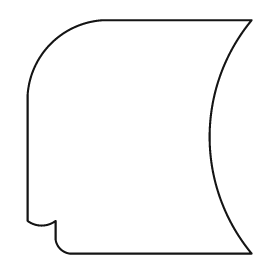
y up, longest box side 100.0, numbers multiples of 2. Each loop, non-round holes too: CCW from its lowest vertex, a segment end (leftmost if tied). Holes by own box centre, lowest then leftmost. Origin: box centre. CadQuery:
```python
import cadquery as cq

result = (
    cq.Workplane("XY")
    .moveTo(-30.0, -50.0)
    .lineTo(48.0, -50.0)
    .threePointArc((30.0, 0.0), (48.0, 50.0))
    .lineTo(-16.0, 50.0)
    .threePointArc((-38.0, 40.0), (-48.0, 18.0))
    .lineTo(-48.0, -36.0)
    .threePointArc((-42.0, -38.0), (-36.0, -36.0))
    .lineTo(-36.0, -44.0)
    .threePointArc((-34.0, -48.0), (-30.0, -50.0))
    .close()
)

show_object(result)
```